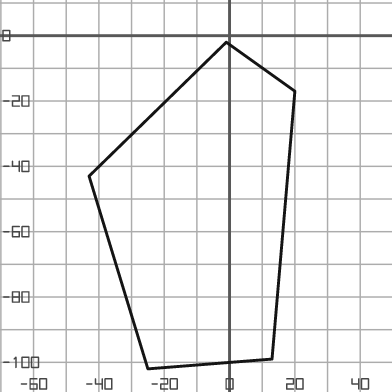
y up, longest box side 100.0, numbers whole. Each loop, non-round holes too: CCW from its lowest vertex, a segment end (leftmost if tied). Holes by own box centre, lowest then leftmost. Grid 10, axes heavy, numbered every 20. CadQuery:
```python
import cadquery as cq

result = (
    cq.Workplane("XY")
    .moveTo(-25.0, -102.0)
    .lineTo(13.0, -99.0)
    .lineTo(20.0, -17.0)
    .lineTo(-1.0, -2.0)
    .lineTo(-43.0, -43.0)
    .close()
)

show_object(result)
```